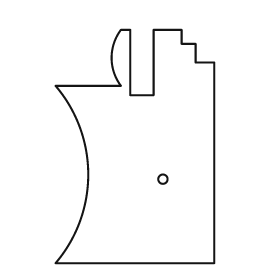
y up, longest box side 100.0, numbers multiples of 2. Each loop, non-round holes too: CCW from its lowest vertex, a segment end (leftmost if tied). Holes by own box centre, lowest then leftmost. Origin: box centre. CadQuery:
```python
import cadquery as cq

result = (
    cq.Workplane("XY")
    .moveTo(-34.0, -50.0)
    .lineTo(34.0, -50.0)
    .lineTo(34.0, 36.0)
    .lineTo(26.0, 36.0)
    .lineTo(26.0, 44.0)
    .lineTo(20.0, 44.0)
    .lineTo(20.0, 50.0)
    .lineTo(8.0, 50.0)
    .lineTo(8.0, 22.0)
    .lineTo(-2.0, 22.0)
    .lineTo(-2.0, 50.0)
    .lineTo(-6.0, 50.0)
    .threePointArc((-10.0, 38.0), (-6.0, 26.0))
    .lineTo(-34.0, 26.0)
    .threePointArc((-20.0, -12.0), (-34.0, -50.0))
    .close()
    .moveTo(12.0, -14.0)
    .circle(2.0)
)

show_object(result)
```